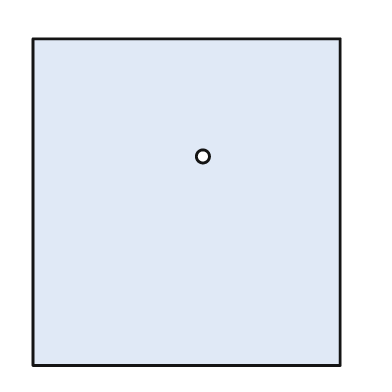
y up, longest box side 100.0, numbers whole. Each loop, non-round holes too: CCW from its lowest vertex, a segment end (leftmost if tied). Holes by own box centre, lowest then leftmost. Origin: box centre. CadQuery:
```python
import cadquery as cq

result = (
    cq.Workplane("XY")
    .moveTo(-47.0, -50.0)
    .lineTo(47.0, -50.0)
    .lineTo(47.0, 50.0)
    .lineTo(-47.0, 50.0)
    .close()
    .moveTo(5.0, 14.0)
    .circle(2.0)
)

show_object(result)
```